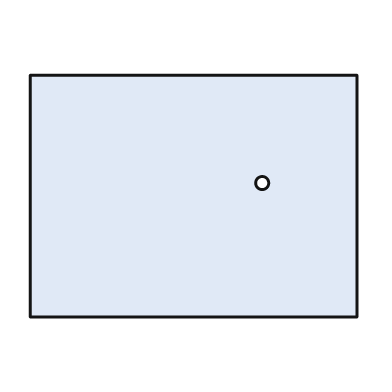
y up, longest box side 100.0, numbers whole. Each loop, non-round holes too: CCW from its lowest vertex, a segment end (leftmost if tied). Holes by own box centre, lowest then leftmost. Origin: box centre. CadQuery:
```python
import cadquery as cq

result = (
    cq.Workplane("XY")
    .moveTo(-50.0, -37.0)
    .lineTo(50.0, -37.0)
    .lineTo(50.0, 37.0)
    .lineTo(-50.0, 37.0)
    .close()
    .moveTo(21.0, 4.0)
    .circle(2.0)
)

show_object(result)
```